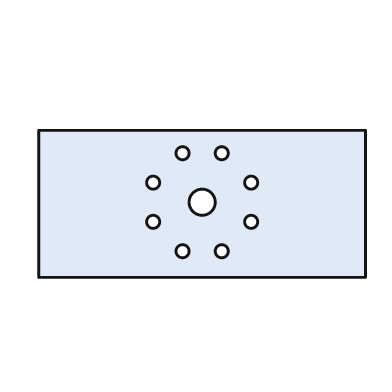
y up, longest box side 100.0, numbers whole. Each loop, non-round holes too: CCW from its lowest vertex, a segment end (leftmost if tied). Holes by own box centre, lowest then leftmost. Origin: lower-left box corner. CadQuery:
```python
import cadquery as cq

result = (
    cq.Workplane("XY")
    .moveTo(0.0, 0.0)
    .lineTo(100.0, 0.0)
    .lineTo(100.0, 45.0)
    .lineTo(0.0, 45.0)
    .close()
    .moveTo(44.0, 8.0)
    .circle(2.0)
    .moveTo(56.0, 8.0)
    .circle(2.0)
    .moveTo(35.0, 17.0)
    .circle(2.0)
    .moveTo(65.0, 17.0)
    .circle(2.0)
    .moveTo(50.0, 23.0)
    .circle(4.0)
    .moveTo(35.0, 29.0)
    .circle(2.0)
    .moveTo(65.0, 29.0)
    .circle(2.0)
    .moveTo(44.0, 38.0)
    .circle(2.0)
    .moveTo(56.0, 38.0)
    .circle(2.0)
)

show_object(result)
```